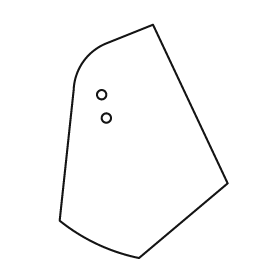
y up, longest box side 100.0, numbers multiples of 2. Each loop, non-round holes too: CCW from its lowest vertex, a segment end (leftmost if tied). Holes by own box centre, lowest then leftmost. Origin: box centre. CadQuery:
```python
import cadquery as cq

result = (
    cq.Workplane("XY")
    .moveTo(-2.0, -50.0)
    .lineTo(36.0, -18.0)
    .lineTo(4.0, 50.0)
    .lineTo(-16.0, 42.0)
    .threePointArc((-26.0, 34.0), (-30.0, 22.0))
    .lineTo(-36.0, -34.0)
    .threePointArc((-20.0, -44.0), (-2.0, -50.0))
    .close()
    .moveTo(-16.0, 10.0)
    .circle(2.0)
    .moveTo(-18.0, 20.0)
    .circle(2.0)
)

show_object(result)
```